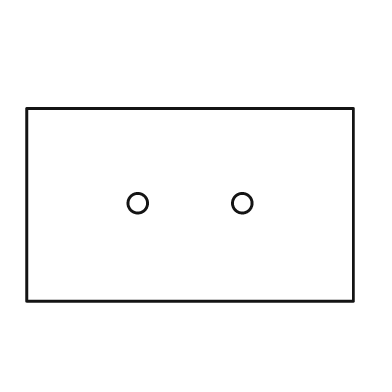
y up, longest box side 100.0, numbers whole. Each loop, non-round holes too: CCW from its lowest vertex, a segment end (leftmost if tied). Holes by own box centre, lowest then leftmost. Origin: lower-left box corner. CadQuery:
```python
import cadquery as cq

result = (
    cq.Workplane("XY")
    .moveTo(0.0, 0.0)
    .lineTo(100.0, 0.0)
    .lineTo(100.0, 59.0)
    .lineTo(0.0, 59.0)
    .close()
    .moveTo(34.0, 30.0)
    .circle(3.0)
    .moveTo(66.0, 30.0)
    .circle(3.0)
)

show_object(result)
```